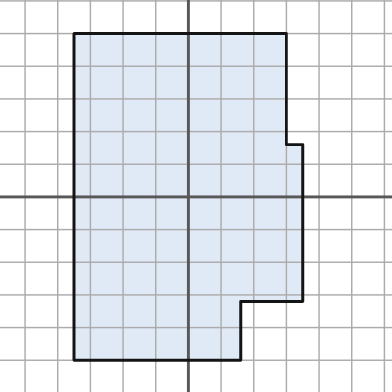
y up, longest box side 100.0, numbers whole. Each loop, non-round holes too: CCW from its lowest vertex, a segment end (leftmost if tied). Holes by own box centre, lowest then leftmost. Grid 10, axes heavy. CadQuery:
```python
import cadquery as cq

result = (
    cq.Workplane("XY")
    .moveTo(-35.0, -50.0)
    .lineTo(16.0, -50.0)
    .lineTo(16.0, -32.0)
    .lineTo(35.0, -32.0)
    .lineTo(35.0, 16.0)
    .lineTo(30.0, 16.0)
    .lineTo(30.0, 50.0)
    .lineTo(-35.0, 50.0)
    .close()
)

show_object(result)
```